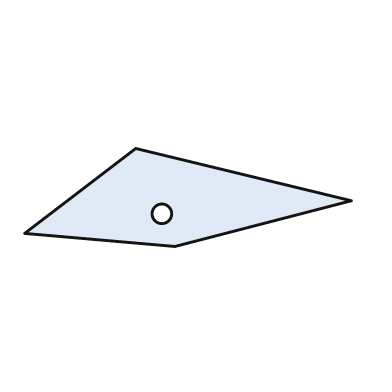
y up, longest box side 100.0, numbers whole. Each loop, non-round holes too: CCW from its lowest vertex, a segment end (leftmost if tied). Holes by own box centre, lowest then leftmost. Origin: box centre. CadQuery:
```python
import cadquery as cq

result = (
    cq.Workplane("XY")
    .moveTo(-4.0, -15.0)
    .lineTo(50.0, -1.0)
    .lineTo(-16.0, 15.0)
    .lineTo(-50.0, -11.0)
    .close()
    .moveTo(-8.0, -5.0)
    .circle(3.0)
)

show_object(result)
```